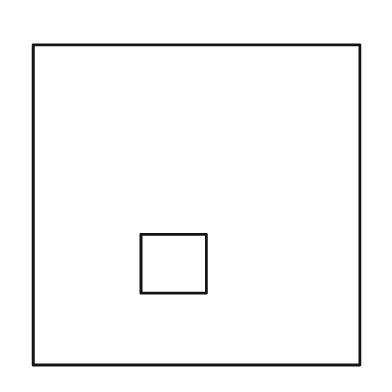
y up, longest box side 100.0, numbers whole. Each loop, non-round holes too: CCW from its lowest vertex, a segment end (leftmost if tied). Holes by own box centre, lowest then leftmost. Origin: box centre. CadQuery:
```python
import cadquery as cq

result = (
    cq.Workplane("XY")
    .moveTo(-50.0, -49.0)
    .lineTo(50.0, -49.0)
    .lineTo(50.0, 49.0)
    .lineTo(-50.0, 49.0)
    .close()
    .moveTo(-17.0, -27.0)
    .lineTo(3.0, -27.0)
    .lineTo(3.0, -9.0)
    .lineTo(-17.0, -9.0)
    .close()
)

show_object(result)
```